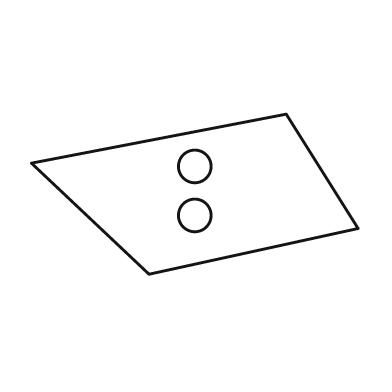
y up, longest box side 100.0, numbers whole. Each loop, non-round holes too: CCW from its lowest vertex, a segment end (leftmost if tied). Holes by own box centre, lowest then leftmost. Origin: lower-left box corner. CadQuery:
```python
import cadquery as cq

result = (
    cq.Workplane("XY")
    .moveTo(36.0, 0.0)
    .lineTo(100.0, 14.0)
    .lineTo(78.0, 49.0)
    .lineTo(0.0, 34.0)
    .close()
    .moveTo(50.0, 18.0)
    .circle(5.0)
    .moveTo(50.0, 33.0)
    .circle(5.0)
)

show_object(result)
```